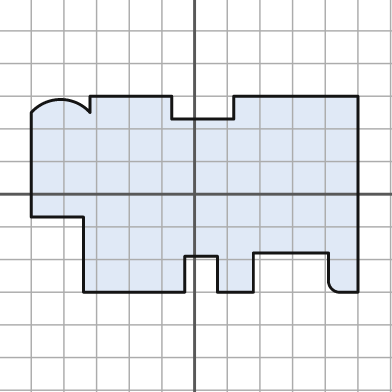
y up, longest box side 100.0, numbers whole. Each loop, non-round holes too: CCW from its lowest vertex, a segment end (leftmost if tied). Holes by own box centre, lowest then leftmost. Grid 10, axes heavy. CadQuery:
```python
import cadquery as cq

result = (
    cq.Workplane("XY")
    .moveTo(-34.0, -30.0)
    .lineTo(-3.0, -30.0)
    .lineTo(-3.0, -19.0)
    .lineTo(7.0, -19.0)
    .lineTo(7.0, -30.0)
    .lineTo(18.0, -30.0)
    .lineTo(18.0, -18.0)
    .lineTo(41.0, -18.0)
    .lineTo(41.0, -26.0)
    .threePointArc((42.0, -29.0), (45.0, -30.0))
    .lineTo(50.0, -30.0)
    .lineTo(50.0, 30.0)
    .lineTo(12.0, 30.0)
    .lineTo(12.0, 23.0)
    .lineTo(-7.0, 23.0)
    .lineTo(-7.0, 30.0)
    .lineTo(-32.0, 30.0)
    .lineTo(-32.0, 25.0)
    .threePointArc((-41.0, 29.0), (-50.0, 25.0))
    .lineTo(-50.0, -7.0)
    .lineTo(-34.0, -7.0)
    .close()
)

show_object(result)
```